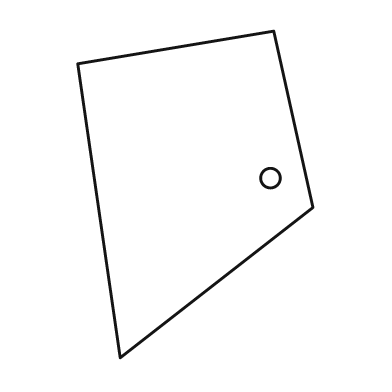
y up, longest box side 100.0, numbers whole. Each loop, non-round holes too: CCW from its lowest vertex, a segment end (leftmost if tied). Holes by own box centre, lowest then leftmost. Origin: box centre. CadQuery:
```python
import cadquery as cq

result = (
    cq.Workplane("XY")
    .moveTo(-23.0, -50.0)
    .lineTo(36.0, -4.0)
    .lineTo(24.0, 50.0)
    .lineTo(-36.0, 40.0)
    .close()
    .moveTo(23.0, 5.0)
    .circle(3.0)
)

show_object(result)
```